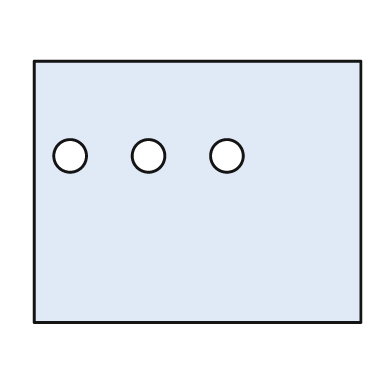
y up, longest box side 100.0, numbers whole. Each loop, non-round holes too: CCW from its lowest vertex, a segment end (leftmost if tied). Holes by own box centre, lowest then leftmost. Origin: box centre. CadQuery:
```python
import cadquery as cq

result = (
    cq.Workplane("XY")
    .moveTo(-50.0, -40.0)
    .lineTo(50.0, -40.0)
    .lineTo(50.0, 40.0)
    .lineTo(-50.0, 40.0)
    .close()
    .moveTo(-39.0, 11.0)
    .circle(5.0)
    .moveTo(-15.0, 11.0)
    .circle(5.0)
    .moveTo(9.0, 11.0)
    .circle(5.0)
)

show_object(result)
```